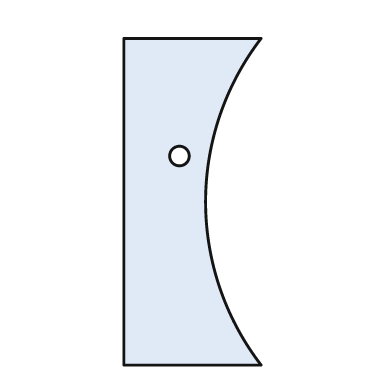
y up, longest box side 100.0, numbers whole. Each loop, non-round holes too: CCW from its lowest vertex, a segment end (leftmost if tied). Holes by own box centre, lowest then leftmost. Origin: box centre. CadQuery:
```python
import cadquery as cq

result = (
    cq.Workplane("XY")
    .moveTo(-21.0, -50.0)
    .lineTo(21.0, -50.0)
    .threePointArc((4.0, 0.0), (21.0, 50.0))
    .lineTo(-21.0, 50.0)
    .close()
    .moveTo(-4.0, 14.0)
    .circle(3.0)
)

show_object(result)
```